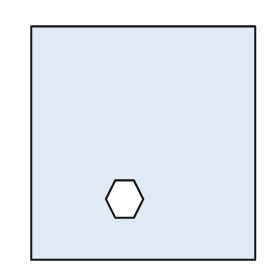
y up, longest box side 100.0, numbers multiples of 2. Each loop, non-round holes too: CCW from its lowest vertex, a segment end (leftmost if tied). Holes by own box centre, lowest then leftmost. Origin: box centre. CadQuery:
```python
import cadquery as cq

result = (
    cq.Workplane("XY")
    .moveTo(-48.0, -50.0)
    .lineTo(48.0, -50.0)
    .lineTo(48.0, 50.0)
    .lineTo(-48.0, 50.0)
    .close()
    .moveTo(-12.0, -32.0)
    .lineTo(-4.0, -32.0)
    .lineTo(0.0, -24.0)
    .lineTo(-4.0, -16.0)
    .lineTo(-12.0, -16.0)
    .lineTo(-16.0, -24.0)
    .close()
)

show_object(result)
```